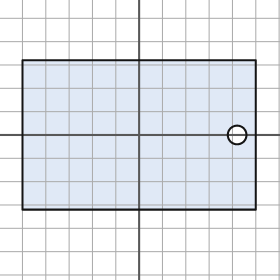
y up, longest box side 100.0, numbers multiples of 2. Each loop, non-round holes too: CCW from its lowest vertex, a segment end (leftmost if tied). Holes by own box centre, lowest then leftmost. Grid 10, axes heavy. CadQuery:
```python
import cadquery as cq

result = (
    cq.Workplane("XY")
    .moveTo(-50.0, -32.0)
    .lineTo(50.0, -32.0)
    .lineTo(50.0, 32.0)
    .lineTo(-50.0, 32.0)
    .close()
    .moveTo(42.0, 0.0)
    .circle(4.0)
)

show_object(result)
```